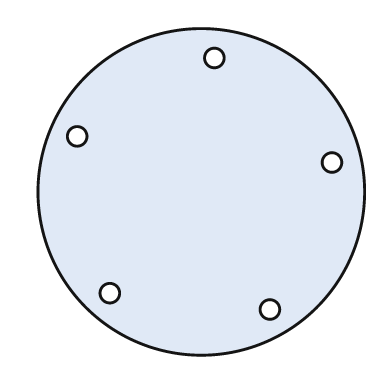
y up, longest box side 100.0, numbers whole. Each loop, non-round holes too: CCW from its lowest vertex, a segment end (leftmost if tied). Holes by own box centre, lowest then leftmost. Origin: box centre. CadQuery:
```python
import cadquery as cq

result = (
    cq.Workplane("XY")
    .moveTo(0.0, 0.0)
    .circle(50.0)
    .moveTo(21.0, -36.0)
    .circle(3.0)
    .moveTo(-28.0, -31.0)
    .circle(3.0)
    .moveTo(40.0, 9.0)
    .circle(3.0)
    .moveTo(-38.0, 17.0)
    .circle(3.0)
    .moveTo(4.0, 41.0)
    .circle(3.0)
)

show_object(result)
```